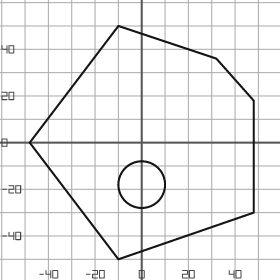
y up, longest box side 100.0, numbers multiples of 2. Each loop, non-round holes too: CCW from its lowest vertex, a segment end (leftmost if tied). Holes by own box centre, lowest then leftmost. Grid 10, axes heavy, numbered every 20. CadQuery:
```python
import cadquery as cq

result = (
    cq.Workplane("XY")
    .moveTo(-10.0, -50.0)
    .lineTo(48.0, -30.0)
    .lineTo(48.0, 18.0)
    .lineTo(32.0, 36.0)
    .lineTo(-10.0, 50.0)
    .lineTo(-48.0, 0.0)
    .close()
    .moveTo(0.0, -18.0)
    .circle(10.0)
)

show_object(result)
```